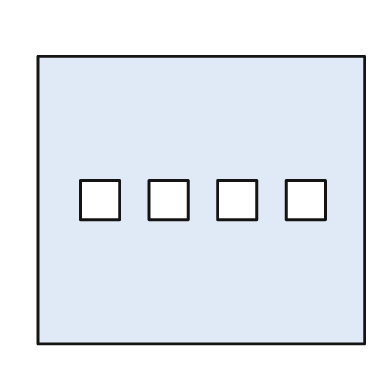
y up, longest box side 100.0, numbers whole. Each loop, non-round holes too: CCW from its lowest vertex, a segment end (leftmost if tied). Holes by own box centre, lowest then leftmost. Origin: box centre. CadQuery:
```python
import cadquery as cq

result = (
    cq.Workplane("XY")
    .moveTo(-50.0, -44.0)
    .lineTo(50.0, -44.0)
    .lineTo(50.0, 44.0)
    .lineTo(-50.0, 44.0)
    .close()
    .moveTo(-37.0, -6.0)
    .lineTo(-25.0, -6.0)
    .lineTo(-25.0, 6.0)
    .lineTo(-37.0, 6.0)
    .close()
    .moveTo(-16.0, -6.0)
    .lineTo(-4.0, -6.0)
    .lineTo(-4.0, 6.0)
    .lineTo(-16.0, 6.0)
    .close()
    .moveTo(5.0, -6.0)
    .lineTo(17.0, -6.0)
    .lineTo(17.0, 6.0)
    .lineTo(5.0, 6.0)
    .close()
    .moveTo(26.0, -6.0)
    .lineTo(38.0, -6.0)
    .lineTo(38.0, 6.0)
    .lineTo(26.0, 6.0)
    .close()
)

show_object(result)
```